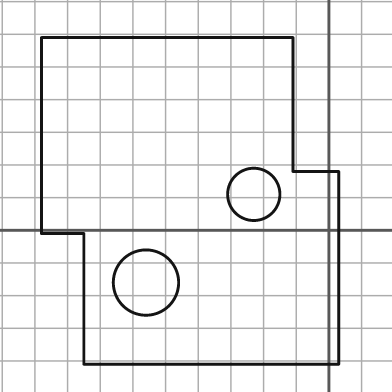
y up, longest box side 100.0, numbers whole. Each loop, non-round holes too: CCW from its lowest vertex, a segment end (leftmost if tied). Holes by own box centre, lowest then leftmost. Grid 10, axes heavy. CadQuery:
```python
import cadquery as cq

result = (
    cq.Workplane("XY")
    .moveTo(-75.0, -41.0)
    .lineTo(3.0, -41.0)
    .lineTo(3.0, 18.0)
    .lineTo(-11.0, 18.0)
    .lineTo(-11.0, 59.0)
    .lineTo(-88.0, 59.0)
    .lineTo(-88.0, -1.0)
    .lineTo(-75.0, -1.0)
    .close()
    .moveTo(-56.0, -16.0)
    .circle(10.0)
    .moveTo(-23.0, 11.0)
    .circle(8.0)
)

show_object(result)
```